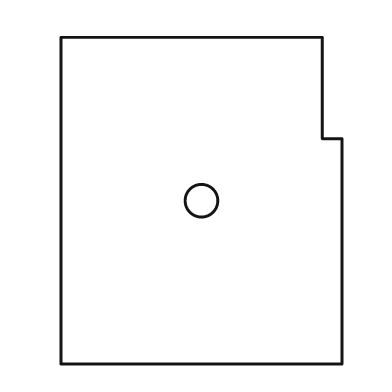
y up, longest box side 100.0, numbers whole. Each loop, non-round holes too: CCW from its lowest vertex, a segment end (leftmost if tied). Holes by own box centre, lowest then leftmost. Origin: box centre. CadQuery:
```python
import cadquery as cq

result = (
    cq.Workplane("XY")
    .moveTo(-43.0, -50.0)
    .lineTo(43.0, -50.0)
    .lineTo(43.0, 19.0)
    .lineTo(37.0, 19.0)
    .lineTo(37.0, 50.0)
    .lineTo(-43.0, 50.0)
    .close()
    .moveTo(0.0, 0.0)
    .circle(5.0)
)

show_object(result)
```